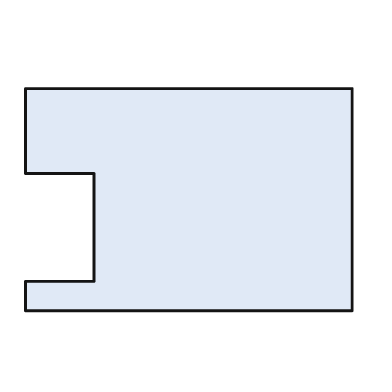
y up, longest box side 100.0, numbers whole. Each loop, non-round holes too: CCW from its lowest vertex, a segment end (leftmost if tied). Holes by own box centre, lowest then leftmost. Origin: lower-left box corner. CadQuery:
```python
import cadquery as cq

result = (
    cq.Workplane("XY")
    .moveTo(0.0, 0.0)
    .lineTo(100.0, 0.0)
    .lineTo(100.0, 68.0)
    .lineTo(0.0, 68.0)
    .lineTo(0.0, 42.0)
    .lineTo(21.0, 42.0)
    .lineTo(21.0, 9.0)
    .lineTo(0.0, 9.0)
    .close()
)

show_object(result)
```